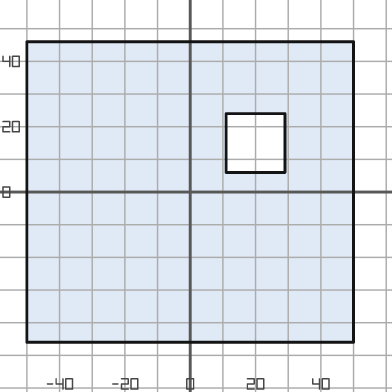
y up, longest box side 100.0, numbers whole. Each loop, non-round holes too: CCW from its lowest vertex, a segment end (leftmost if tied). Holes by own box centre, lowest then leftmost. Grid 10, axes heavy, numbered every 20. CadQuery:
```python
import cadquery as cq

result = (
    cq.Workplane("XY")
    .moveTo(-50.0, -46.0)
    .lineTo(50.0, -46.0)
    .lineTo(50.0, 46.0)
    .lineTo(-50.0, 46.0)
    .close()
    .moveTo(11.0, 6.0)
    .lineTo(29.0, 6.0)
    .lineTo(29.0, 24.0)
    .lineTo(11.0, 24.0)
    .close()
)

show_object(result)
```